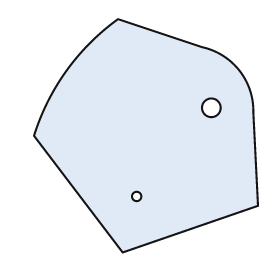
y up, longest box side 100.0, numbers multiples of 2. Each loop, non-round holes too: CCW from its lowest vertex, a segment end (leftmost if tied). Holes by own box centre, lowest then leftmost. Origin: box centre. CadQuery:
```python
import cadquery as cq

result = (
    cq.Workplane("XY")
    .moveTo(-10.0, -50.0)
    .lineTo(48.0, -30.0)
    .lineTo(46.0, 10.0)
    .threePointArc((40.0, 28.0), (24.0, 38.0))
    .lineTo(-12.0, 50.0)
    .threePointArc((-34.0, 28.0), (-48.0, 0.0))
    .close()
    .moveTo(-4.0, -26.0)
    .circle(2.0)
    .moveTo(28.0, 12.0)
    .circle(4.0)
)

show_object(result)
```